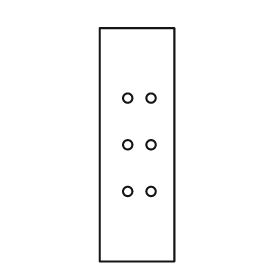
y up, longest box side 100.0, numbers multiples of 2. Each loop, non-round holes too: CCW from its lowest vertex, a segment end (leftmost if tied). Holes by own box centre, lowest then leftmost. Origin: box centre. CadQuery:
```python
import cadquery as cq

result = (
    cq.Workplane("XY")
    .moveTo(-16.0, -50.0)
    .lineTo(16.0, -50.0)
    .lineTo(16.0, 50.0)
    .lineTo(-16.0, 50.0)
    .close()
    .moveTo(-4.0, -20.0)
    .circle(2.0)
    .moveTo(6.0, -20.0)
    .circle(2.0)
    .moveTo(-4.0, 0.0)
    .circle(2.0)
    .moveTo(6.0, 0.0)
    .circle(2.0)
    .moveTo(-4.0, 20.0)
    .circle(2.0)
    .moveTo(6.0, 20.0)
    .circle(2.0)
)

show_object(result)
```